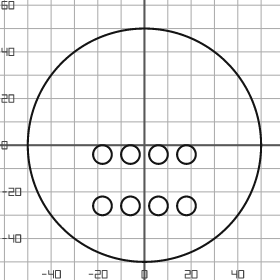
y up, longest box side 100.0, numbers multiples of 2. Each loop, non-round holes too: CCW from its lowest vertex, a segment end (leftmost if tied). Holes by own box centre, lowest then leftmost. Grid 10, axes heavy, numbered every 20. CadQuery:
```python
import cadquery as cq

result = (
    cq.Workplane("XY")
    .moveTo(0.0, 0.0)
    .circle(50.0)
    .moveTo(-18.0, -26.0)
    .circle(4.0)
    .moveTo(-6.0, -26.0)
    .circle(4.0)
    .moveTo(6.0, -26.0)
    .circle(4.0)
    .moveTo(18.0, -26.0)
    .circle(4.0)
    .moveTo(-18.0, -4.0)
    .circle(4.0)
    .moveTo(-6.0, -4.0)
    .circle(4.0)
    .moveTo(6.0, -4.0)
    .circle(4.0)
    .moveTo(18.0, -4.0)
    .circle(4.0)
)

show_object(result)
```